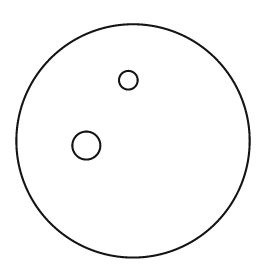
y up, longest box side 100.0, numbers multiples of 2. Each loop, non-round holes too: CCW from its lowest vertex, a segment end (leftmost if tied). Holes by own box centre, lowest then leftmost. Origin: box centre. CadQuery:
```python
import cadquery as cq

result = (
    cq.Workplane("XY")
    .moveTo(0.0, 0.0)
    .circle(50.0)
    .moveTo(-20.0, -2.0)
    .circle(6.0)
    .moveTo(-2.0, 26.0)
    .circle(4.0)
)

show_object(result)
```